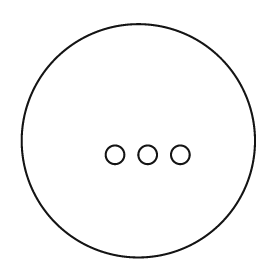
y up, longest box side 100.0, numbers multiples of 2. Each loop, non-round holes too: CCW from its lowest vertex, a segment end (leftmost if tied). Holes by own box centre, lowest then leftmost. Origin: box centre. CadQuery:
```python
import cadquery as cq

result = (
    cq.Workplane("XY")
    .moveTo(0.0, 0.0)
    .circle(50.0)
    .moveTo(-10.0, -6.0)
    .circle(4.0)
    .moveTo(4.0, -6.0)
    .circle(4.0)
    .moveTo(18.0, -6.0)
    .circle(4.0)
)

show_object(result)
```